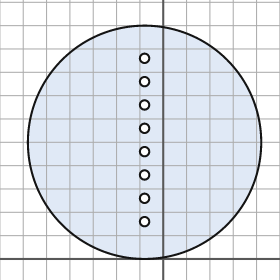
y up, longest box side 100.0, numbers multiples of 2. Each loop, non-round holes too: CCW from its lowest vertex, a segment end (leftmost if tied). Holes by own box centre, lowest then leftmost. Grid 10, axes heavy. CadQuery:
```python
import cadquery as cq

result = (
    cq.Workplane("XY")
    .moveTo(-8.0, 50.0)
    .circle(50.0)
    .moveTo(-8.0, 16.0)
    .circle(2.0)
    .moveTo(-8.0, 26.0)
    .circle(2.0)
    .moveTo(-8.0, 36.0)
    .circle(2.0)
    .moveTo(-8.0, 46.0)
    .circle(2.0)
    .moveTo(-8.0, 56.0)
    .circle(2.0)
    .moveTo(-8.0, 66.0)
    .circle(2.0)
    .moveTo(-8.0, 76.0)
    .circle(2.0)
    .moveTo(-8.0, 86.0)
    .circle(2.0)
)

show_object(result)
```